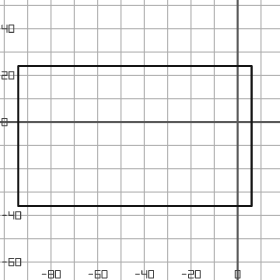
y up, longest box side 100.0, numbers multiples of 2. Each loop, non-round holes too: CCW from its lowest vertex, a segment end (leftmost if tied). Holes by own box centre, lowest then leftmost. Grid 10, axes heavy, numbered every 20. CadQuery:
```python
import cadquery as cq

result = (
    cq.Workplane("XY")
    .moveTo(-94.0, -36.0)
    .lineTo(6.0, -36.0)
    .lineTo(6.0, 24.0)
    .lineTo(-94.0, 24.0)
    .close()
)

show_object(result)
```